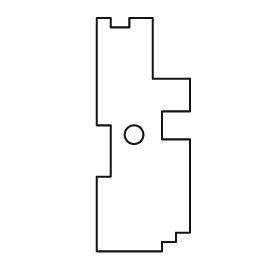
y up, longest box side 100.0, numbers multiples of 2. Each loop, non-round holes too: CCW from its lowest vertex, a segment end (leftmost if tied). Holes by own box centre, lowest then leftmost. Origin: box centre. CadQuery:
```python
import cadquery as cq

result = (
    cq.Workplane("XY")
    .moveTo(-20.0, -50.0)
    .lineTo(8.0, -50.0)
    .lineTo(8.0, -46.0)
    .lineTo(14.0, -46.0)
    .lineTo(14.0, -42.0)
    .lineTo(20.0, -42.0)
    .lineTo(20.0, -2.0)
    .lineTo(8.0, -2.0)
    .lineTo(8.0, 10.0)
    .lineTo(20.0, 10.0)
    .lineTo(20.0, 24.0)
    .lineTo(4.0, 24.0)
    .lineTo(4.0, 50.0)
    .lineTo(-6.0, 50.0)
    .lineTo(-6.0, 46.0)
    .lineTo(-14.0, 46.0)
    .lineTo(-14.0, 50.0)
    .lineTo(-20.0, 50.0)
    .lineTo(-20.0, 4.0)
    .lineTo(-14.0, 4.0)
    .lineTo(-14.0, -18.0)
    .lineTo(-20.0, -18.0)
    .close()
    .moveTo(-4.0, 0.0)
    .circle(4.0)
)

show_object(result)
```